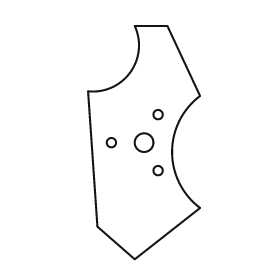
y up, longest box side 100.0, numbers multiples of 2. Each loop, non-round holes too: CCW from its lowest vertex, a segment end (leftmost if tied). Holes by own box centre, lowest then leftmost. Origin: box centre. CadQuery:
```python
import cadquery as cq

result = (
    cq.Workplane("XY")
    .moveTo(-4.0, -50.0)
    .lineTo(24.0, -28.0)
    .threePointArc((12.0, -4.0), (24.0, 20.0))
    .lineTo(10.0, 50.0)
    .lineTo(-4.0, 50.0)
    .threePointArc((-6.0, 30.0), (-24.0, 22.0))
    .lineTo(-20.0, -36.0)
    .close()
    .moveTo(6.0, -12.0)
    .circle(2.0)
    .moveTo(-14.0, 0.0)
    .circle(2.0)
    .moveTo(0.0, 0.0)
    .circle(4.0)
    .moveTo(6.0, 12.0)
    .circle(2.0)
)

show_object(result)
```